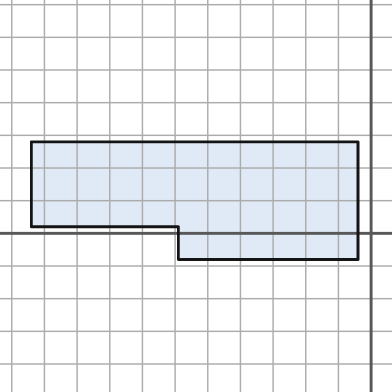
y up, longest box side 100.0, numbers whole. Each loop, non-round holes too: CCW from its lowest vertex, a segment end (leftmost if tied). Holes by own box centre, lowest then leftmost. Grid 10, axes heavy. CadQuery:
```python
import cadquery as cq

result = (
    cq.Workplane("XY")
    .moveTo(-59.0, -8.0)
    .lineTo(-4.0, -8.0)
    .lineTo(-4.0, 28.0)
    .lineTo(-104.0, 28.0)
    .lineTo(-104.0, 2.0)
    .lineTo(-59.0, 2.0)
    .close()
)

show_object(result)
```